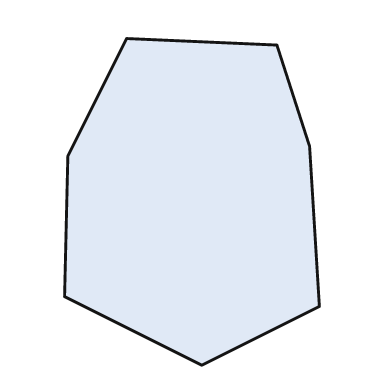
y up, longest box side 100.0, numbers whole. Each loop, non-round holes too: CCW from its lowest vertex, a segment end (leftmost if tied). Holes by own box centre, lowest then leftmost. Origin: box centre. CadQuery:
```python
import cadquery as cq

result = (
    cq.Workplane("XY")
    .moveTo(3.0, -50.0)
    .lineTo(39.0, -32.0)
    .lineTo(36.0, 17.0)
    .lineTo(26.0, 48.0)
    .lineTo(-20.0, 50.0)
    .lineTo(-38.0, 14.0)
    .lineTo(-39.0, -29.0)
    .close()
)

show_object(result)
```